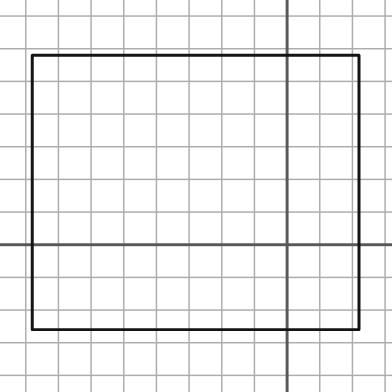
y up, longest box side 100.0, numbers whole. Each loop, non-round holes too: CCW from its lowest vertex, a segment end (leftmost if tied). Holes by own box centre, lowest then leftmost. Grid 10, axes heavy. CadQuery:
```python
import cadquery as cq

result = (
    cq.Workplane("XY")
    .moveTo(-78.0, -26.0)
    .lineTo(22.0, -26.0)
    .lineTo(22.0, 58.0)
    .lineTo(-78.0, 58.0)
    .close()
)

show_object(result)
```